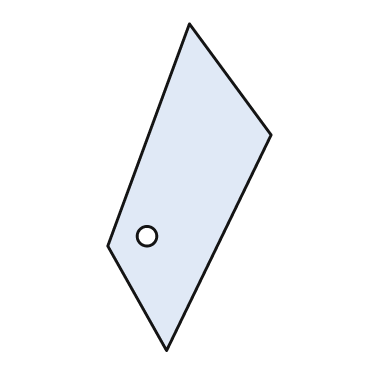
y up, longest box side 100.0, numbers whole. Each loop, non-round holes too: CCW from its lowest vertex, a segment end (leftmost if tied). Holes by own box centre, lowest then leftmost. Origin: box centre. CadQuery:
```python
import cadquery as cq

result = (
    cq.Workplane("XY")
    .moveTo(-7.0, -50.0)
    .lineTo(25.0, 16.0)
    .lineTo(0.0, 50.0)
    .lineTo(-25.0, -18.0)
    .close()
    .moveTo(-13.0, -15.0)
    .circle(3.0)
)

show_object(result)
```